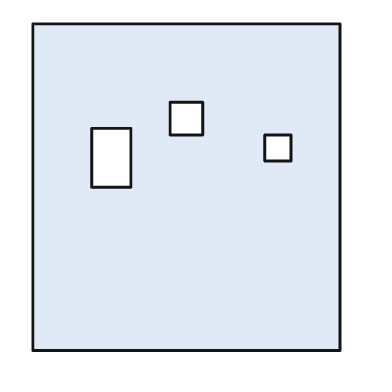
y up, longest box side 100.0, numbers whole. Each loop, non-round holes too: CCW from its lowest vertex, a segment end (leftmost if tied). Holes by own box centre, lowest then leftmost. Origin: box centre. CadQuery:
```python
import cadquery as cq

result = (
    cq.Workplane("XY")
    .moveTo(-47.0, -50.0)
    .lineTo(47.0, -50.0)
    .lineTo(47.0, 50.0)
    .lineTo(-47.0, 50.0)
    .close()
    .moveTo(-29.0, 0.0)
    .lineTo(-17.0, 0.0)
    .lineTo(-17.0, 18.0)
    .lineTo(-29.0, 18.0)
    .close()
    .moveTo(24.0, 8.0)
    .lineTo(32.0, 8.0)
    .lineTo(32.0, 16.0)
    .lineTo(24.0, 16.0)
    .close()
    .moveTo(-5.0, 16.0)
    .lineTo(5.0, 16.0)
    .lineTo(5.0, 26.0)
    .lineTo(-5.0, 26.0)
    .close()
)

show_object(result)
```